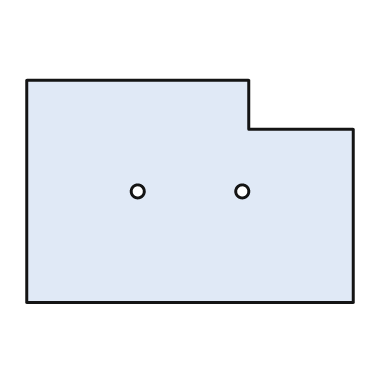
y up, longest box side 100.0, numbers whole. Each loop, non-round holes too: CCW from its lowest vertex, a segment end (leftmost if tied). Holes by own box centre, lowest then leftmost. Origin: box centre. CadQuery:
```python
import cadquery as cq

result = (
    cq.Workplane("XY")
    .moveTo(-50.0, -34.0)
    .lineTo(50.0, -34.0)
    .lineTo(50.0, 19.0)
    .lineTo(18.0, 19.0)
    .lineTo(18.0, 34.0)
    .lineTo(-50.0, 34.0)
    .close()
    .moveTo(-16.0, 0.0)
    .circle(2.0)
    .moveTo(16.0, 0.0)
    .circle(2.0)
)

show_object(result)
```